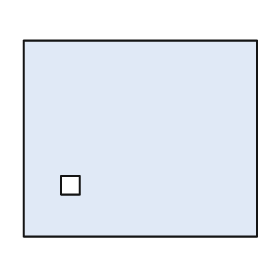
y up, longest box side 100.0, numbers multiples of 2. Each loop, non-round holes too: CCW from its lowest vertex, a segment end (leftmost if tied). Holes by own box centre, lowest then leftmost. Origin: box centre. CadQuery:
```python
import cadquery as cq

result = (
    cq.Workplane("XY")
    .moveTo(-50.0, -42.0)
    .lineTo(50.0, -42.0)
    .lineTo(50.0, 42.0)
    .lineTo(-50.0, 42.0)
    .close()
    .moveTo(-34.0, -24.0)
    .lineTo(-26.0, -24.0)
    .lineTo(-26.0, -16.0)
    .lineTo(-34.0, -16.0)
    .close()
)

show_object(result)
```